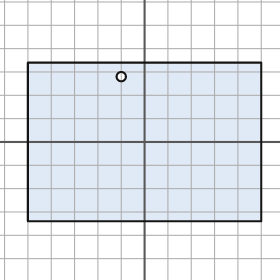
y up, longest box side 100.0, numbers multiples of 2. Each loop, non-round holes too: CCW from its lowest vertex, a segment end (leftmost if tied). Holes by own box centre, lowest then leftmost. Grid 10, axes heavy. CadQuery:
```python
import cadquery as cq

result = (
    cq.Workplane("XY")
    .moveTo(-50.0, -34.0)
    .lineTo(50.0, -34.0)
    .lineTo(50.0, 34.0)
    .lineTo(-50.0, 34.0)
    .close()
    .moveTo(-10.0, 28.0)
    .circle(2.0)
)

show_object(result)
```